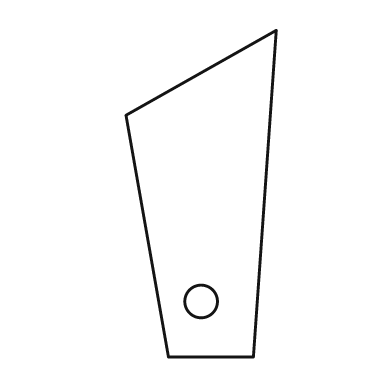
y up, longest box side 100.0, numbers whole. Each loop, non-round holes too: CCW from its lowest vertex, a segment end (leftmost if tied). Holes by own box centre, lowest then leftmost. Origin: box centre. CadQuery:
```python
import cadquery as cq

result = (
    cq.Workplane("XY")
    .moveTo(-10.0, -50.0)
    .lineTo(16.0, -50.0)
    .lineTo(23.0, 50.0)
    .lineTo(-23.0, 24.0)
    .close()
    .moveTo(0.0, -33.0)
    .circle(5.0)
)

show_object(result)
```